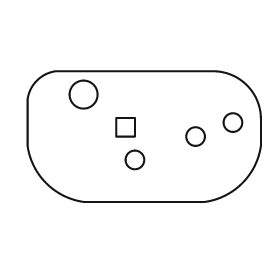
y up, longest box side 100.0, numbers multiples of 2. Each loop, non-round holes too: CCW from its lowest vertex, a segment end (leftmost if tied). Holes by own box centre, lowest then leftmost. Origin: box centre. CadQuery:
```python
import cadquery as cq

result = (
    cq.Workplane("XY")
    .moveTo(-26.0, -28.0)
    .lineTo(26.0, -28.0)
    .threePointArc((42.0, -20.0), (50.0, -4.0))
    .lineTo(50.0, 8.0)
    .threePointArc((44.0, 22.0), (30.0, 28.0))
    .lineTo(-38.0, 28.0)
    .threePointArc((-46.0, 24.0), (-50.0, 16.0))
    .lineTo(-50.0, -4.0)
    .threePointArc((-42.0, -20.0), (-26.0, -28.0))
    .close()
    .moveTo(-4.0, -10.0)
    .circle(4.0)
    .moveTo(22.0, 0.0)
    .circle(4.0)
    .moveTo(-12.0, 0.0)
    .lineTo(-4.0, 0.0)
    .lineTo(-4.0, 8.0)
    .lineTo(-12.0, 8.0)
    .close()
    .moveTo(38.0, 6.0)
    .circle(4.0)
    .moveTo(-26.0, 18.0)
    .circle(6.0)
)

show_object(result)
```